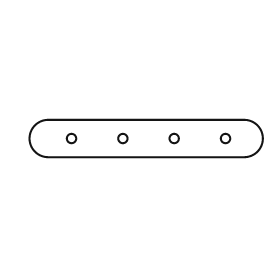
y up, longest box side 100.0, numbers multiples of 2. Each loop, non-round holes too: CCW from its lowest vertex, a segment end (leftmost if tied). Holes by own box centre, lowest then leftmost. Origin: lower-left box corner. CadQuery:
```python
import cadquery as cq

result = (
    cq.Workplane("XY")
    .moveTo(8.0, 0.0)
    .lineTo(92.0, 0.0)
    .threePointArc((100.0, 8.0), (92.0, 16.0))
    .lineTo(8.0, 16.0)
    .threePointArc((0.0, 8.0), (8.0, 0.0))
    .close()
    .moveTo(18.0, 8.0)
    .circle(2.0)
    .moveTo(40.0, 8.0)
    .circle(2.0)
    .moveTo(62.0, 8.0)
    .circle(2.0)
    .moveTo(84.0, 8.0)
    .circle(2.0)
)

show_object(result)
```